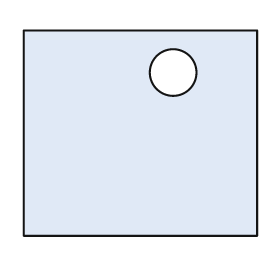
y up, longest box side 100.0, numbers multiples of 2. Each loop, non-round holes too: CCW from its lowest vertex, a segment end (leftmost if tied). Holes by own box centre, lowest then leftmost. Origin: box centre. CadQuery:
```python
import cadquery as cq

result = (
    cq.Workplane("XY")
    .moveTo(-50.0, -44.0)
    .lineTo(50.0, -44.0)
    .lineTo(50.0, 44.0)
    .lineTo(-50.0, 44.0)
    .close()
    .moveTo(14.0, 26.0)
    .circle(10.0)
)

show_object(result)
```